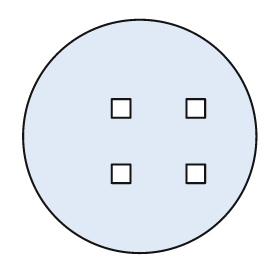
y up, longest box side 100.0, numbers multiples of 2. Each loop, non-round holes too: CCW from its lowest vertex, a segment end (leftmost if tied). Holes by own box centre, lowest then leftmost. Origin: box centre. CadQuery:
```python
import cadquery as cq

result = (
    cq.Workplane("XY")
    .moveTo(0.0, 0.0)
    .circle(50.0)
    .moveTo(-12.0, -20.0)
    .lineTo(-4.0, -20.0)
    .lineTo(-4.0, -12.0)
    .lineTo(-12.0, -12.0)
    .close()
    .moveTo(20.0, -20.0)
    .lineTo(28.0, -20.0)
    .lineTo(28.0, -12.0)
    .lineTo(20.0, -12.0)
    .close()
    .moveTo(-12.0, 8.0)
    .lineTo(-4.0, 8.0)
    .lineTo(-4.0, 16.0)
    .lineTo(-12.0, 16.0)
    .close()
    .moveTo(20.0, 8.0)
    .lineTo(28.0, 8.0)
    .lineTo(28.0, 16.0)
    .lineTo(20.0, 16.0)
    .close()
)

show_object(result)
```